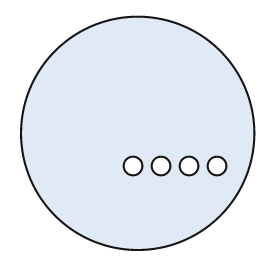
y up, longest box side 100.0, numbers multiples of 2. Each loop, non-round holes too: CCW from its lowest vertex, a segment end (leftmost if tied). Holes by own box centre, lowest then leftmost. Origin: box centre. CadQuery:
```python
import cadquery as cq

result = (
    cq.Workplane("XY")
    .moveTo(0.0, 0.0)
    .circle(50.0)
    .moveTo(-2.0, -14.0)
    .circle(4.0)
    .moveTo(10.0, -14.0)
    .circle(4.0)
    .moveTo(22.0, -14.0)
    .circle(4.0)
    .moveTo(34.0, -14.0)
    .circle(4.0)
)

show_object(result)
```